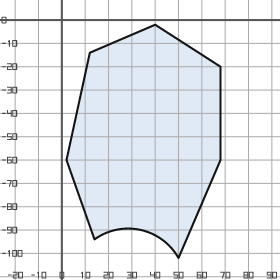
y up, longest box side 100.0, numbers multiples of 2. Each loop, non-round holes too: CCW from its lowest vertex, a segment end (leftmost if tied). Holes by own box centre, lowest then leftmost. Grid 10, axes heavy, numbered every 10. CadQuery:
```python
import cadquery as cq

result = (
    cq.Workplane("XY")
    .moveTo(50.0, -102.0)
    .lineTo(68.0, -60.0)
    .lineTo(68.0, -20.0)
    .lineTo(40.0, -2.0)
    .lineTo(12.0, -14.0)
    .lineTo(2.0, -60.0)
    .lineTo(14.0, -94.0)
    .threePointArc((34.0, -90.0), (50.0, -102.0))
    .close()
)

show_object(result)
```